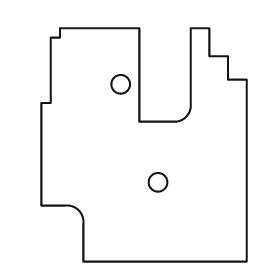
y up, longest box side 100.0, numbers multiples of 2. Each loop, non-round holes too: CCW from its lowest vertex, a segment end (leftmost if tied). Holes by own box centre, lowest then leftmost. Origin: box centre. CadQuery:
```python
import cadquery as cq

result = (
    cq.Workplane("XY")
    .moveTo(-26.0, -50.0)
    .lineTo(44.0, -50.0)
    .lineTo(44.0, 28.0)
    .lineTo(36.0, 28.0)
    .lineTo(36.0, 38.0)
    .lineTo(28.0, 38.0)
    .lineTo(28.0, 50.0)
    .lineTo(20.0, 50.0)
    .lineTo(20.0, 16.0)
    .threePointArc((18.0, 12.0), (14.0, 10.0))
    .lineTo(-2.0, 10.0)
    .lineTo(-2.0, 50.0)
    .lineTo(-36.0, 50.0)
    .lineTo(-36.0, 46.0)
    .lineTo(-40.0, 46.0)
    .lineTo(-40.0, 18.0)
    .lineTo(-44.0, 18.0)
    .lineTo(-44.0, -26.0)
    .lineTo(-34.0, -26.0)
    .threePointArc((-28.0, -28.0), (-26.0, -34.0))
    .close()
    .moveTo(6.0, -16.0)
    .circle(4.0)
    .moveTo(-10.0, 26.0)
    .circle(4.0)
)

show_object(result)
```